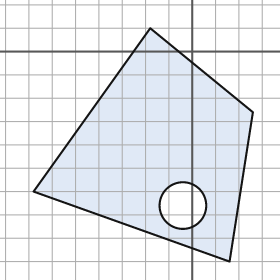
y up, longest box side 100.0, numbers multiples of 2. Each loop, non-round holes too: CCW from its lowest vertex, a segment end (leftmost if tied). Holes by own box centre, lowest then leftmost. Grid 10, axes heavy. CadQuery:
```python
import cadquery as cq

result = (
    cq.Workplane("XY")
    .moveTo(16.0, -90.0)
    .lineTo(26.0, -26.0)
    .lineTo(-18.0, 10.0)
    .lineTo(-68.0, -60.0)
    .close()
    .moveTo(-4.0, -66.0)
    .circle(10.0)
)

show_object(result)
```